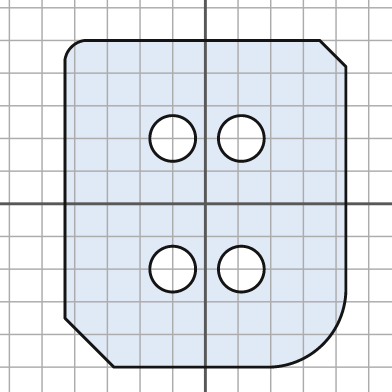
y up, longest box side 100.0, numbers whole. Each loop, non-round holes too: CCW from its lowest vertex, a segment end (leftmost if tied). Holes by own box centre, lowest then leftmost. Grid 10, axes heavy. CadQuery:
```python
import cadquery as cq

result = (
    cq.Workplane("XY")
    .moveTo(-28.0, -50.0)
    .lineTo(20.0, -50.0)
    .threePointArc((36.0, -43.0), (43.0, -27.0))
    .lineTo(43.0, 42.0)
    .lineTo(35.0, 50.0)
    .lineTo(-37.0, 50.0)
    .threePointArc((-41.0, 48.0), (-43.0, 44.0))
    .lineTo(-43.0, -35.0)
    .close()
    .moveTo(-10.0, -20.0)
    .circle(7.0)
    .moveTo(11.0, -20.0)
    .circle(7.0)
    .moveTo(-10.0, 20.0)
    .circle(7.0)
    .moveTo(11.0, 20.0)
    .circle(7.0)
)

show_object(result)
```